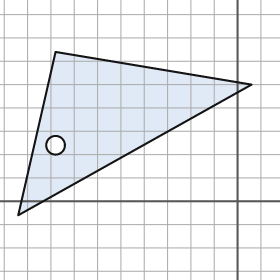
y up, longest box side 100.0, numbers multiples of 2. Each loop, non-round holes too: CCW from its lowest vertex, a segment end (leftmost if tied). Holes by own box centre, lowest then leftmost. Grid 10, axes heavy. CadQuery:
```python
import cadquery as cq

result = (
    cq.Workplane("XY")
    .moveTo(-94.0, -6.0)
    .lineTo(6.0, 50.0)
    .lineTo(-78.0, 64.0)
    .close()
    .moveTo(-78.0, 24.0)
    .circle(4.0)
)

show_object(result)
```